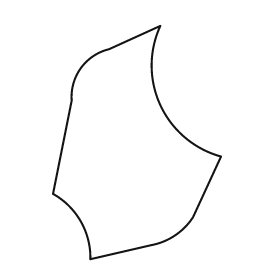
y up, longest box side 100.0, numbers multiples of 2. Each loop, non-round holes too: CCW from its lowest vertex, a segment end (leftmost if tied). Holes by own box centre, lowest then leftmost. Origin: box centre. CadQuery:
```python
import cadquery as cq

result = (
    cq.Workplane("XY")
    .moveTo(-20.0, -50.0)
    .lineTo(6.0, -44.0)
    .threePointArc((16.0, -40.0), (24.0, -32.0))
    .lineTo(36.0, -6.0)
    .threePointArc((10.0, 16.0), (10.0, 50.0))
    .lineTo(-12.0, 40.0)
    .threePointArc((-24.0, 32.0), (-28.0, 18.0))
    .lineTo(-36.0, -22.0)
    .threePointArc((-24.0, -34.0), (-20.0, -50.0))
    .close()
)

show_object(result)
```